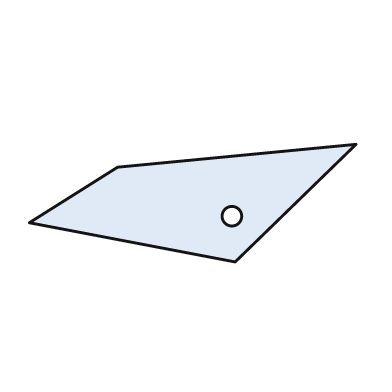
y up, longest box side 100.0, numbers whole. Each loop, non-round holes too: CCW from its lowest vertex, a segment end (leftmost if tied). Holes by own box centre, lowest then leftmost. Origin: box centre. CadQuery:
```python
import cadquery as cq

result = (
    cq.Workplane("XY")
    .moveTo(13.0, -18.0)
    .lineTo(50.0, 18.0)
    .lineTo(-23.0, 11.0)
    .lineTo(-50.0, -6.0)
    .close()
    .moveTo(12.0, -4.0)
    .circle(3.0)
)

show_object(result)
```